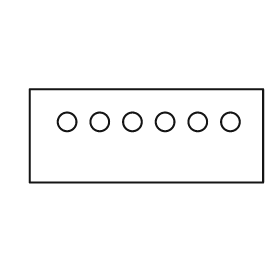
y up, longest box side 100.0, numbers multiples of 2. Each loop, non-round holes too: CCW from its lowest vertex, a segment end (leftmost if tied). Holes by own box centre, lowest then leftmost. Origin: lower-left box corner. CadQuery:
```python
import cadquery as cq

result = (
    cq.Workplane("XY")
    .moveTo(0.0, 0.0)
    .lineTo(100.0, 0.0)
    .lineTo(100.0, 40.0)
    .lineTo(0.0, 40.0)
    .close()
    .moveTo(16.0, 26.0)
    .circle(4.0)
    .moveTo(30.0, 26.0)
    .circle(4.0)
    .moveTo(44.0, 26.0)
    .circle(4.0)
    .moveTo(58.0, 26.0)
    .circle(4.0)
    .moveTo(72.0, 26.0)
    .circle(4.0)
    .moveTo(86.0, 26.0)
    .circle(4.0)
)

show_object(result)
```